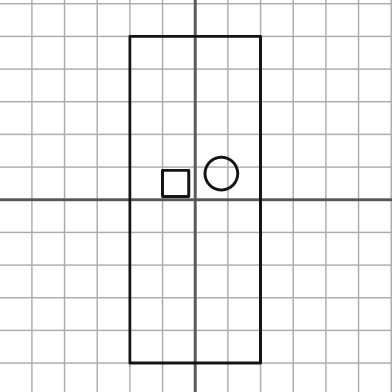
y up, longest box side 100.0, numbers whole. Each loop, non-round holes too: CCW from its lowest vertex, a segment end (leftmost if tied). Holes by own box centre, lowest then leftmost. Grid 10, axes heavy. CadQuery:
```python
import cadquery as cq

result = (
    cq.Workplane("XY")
    .moveTo(-20.0, -50.0)
    .lineTo(20.0, -50.0)
    .lineTo(20.0, 50.0)
    .lineTo(-20.0, 50.0)
    .close()
    .moveTo(-10.0, 1.0)
    .lineTo(-2.0, 1.0)
    .lineTo(-2.0, 9.0)
    .lineTo(-10.0, 9.0)
    .close()
    .moveTo(8.0, 8.0)
    .circle(5.0)
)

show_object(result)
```